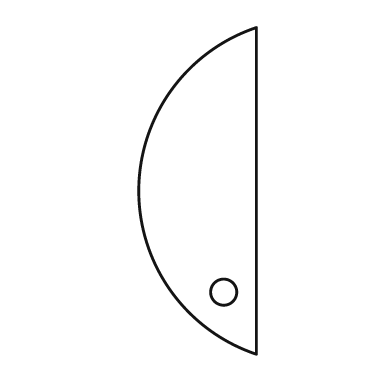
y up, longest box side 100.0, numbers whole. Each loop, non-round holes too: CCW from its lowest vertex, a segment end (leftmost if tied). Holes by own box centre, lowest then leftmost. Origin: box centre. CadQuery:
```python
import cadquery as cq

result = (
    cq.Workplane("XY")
    .moveTo(18.0, -50.0)
    .lineTo(18.0, 50.0)
    .threePointArc((-18.0, 0.0), (18.0, -50.0))
    .close()
    .moveTo(8.0, -31.0)
    .circle(4.0)
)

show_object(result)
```